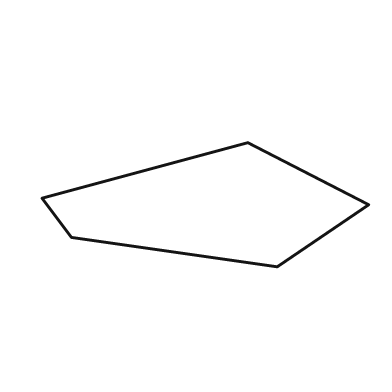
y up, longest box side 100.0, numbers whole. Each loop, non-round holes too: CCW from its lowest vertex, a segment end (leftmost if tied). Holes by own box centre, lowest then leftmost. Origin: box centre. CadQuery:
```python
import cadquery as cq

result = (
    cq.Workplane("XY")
    .moveTo(22.0, -19.0)
    .lineTo(50.0, 0.0)
    .lineTo(13.0, 19.0)
    .lineTo(-50.0, 2.0)
    .lineTo(-41.0, -10.0)
    .close()
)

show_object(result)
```